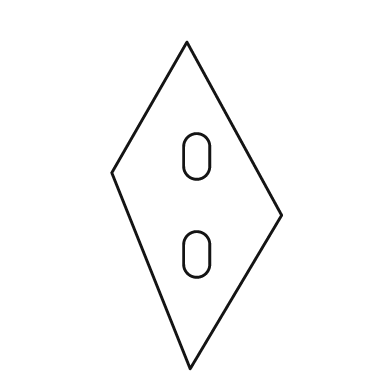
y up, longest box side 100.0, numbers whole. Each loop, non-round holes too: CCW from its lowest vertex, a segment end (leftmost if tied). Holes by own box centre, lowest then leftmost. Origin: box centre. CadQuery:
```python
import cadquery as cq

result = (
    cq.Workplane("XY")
    .moveTo(-2.0, -50.0)
    .lineTo(26.0, -3.0)
    .lineTo(-3.0, 50.0)
    .lineTo(-26.0, 10.0)
    .close()
    .moveTo(-4.0, -18.0)
    .threePointArc((0.0, -22.0), (4.0, -18.0))
    .lineTo(4.0, -12.0)
    .threePointArc((0.0, -8.0), (-4.0, -12.0))
    .close()
    .moveTo(-4.0, 12.0)
    .threePointArc((0.0, 8.0), (4.0, 12.0))
    .lineTo(4.0, 18.0)
    .threePointArc((0.0, 22.0), (-4.0, 18.0))
    .close()
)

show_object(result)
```